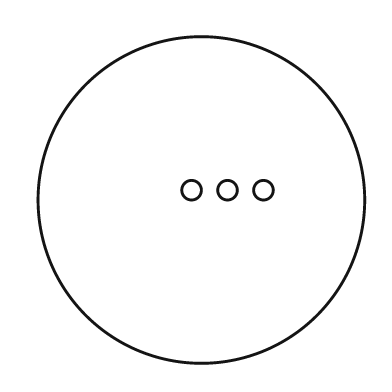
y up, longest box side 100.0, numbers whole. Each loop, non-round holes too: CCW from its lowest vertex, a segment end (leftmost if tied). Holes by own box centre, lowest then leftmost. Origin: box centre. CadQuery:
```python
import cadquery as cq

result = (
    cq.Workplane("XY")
    .moveTo(0.0, 0.0)
    .circle(50.0)
    .moveTo(-3.0, 3.0)
    .circle(3.0)
    .moveTo(8.0, 3.0)
    .circle(3.0)
    .moveTo(19.0, 3.0)
    .circle(3.0)
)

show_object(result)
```